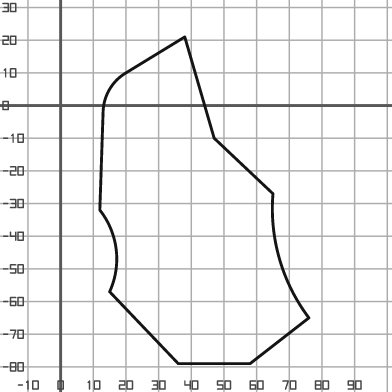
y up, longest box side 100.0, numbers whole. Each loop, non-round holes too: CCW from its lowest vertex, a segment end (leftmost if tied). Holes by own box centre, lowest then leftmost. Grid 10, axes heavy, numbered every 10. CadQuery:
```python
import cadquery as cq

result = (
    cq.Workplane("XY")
    .moveTo(36.0, -79.0)
    .lineTo(58.0, -79.0)
    .lineTo(76.0, -65.0)
    .threePointArc((67.0, -47.0), (65.0, -27.0))
    .lineTo(47.0, -10.0)
    .lineTo(38.0, 21.0)
    .lineTo(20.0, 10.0)
    .threePointArc((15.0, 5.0), (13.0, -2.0))
    .lineTo(12.0, -32.0)
    .threePointArc((17.0, -44.0), (15.0, -57.0))
    .close()
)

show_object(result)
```